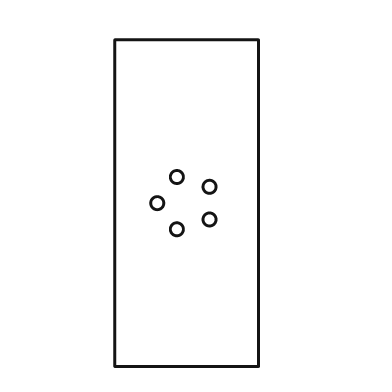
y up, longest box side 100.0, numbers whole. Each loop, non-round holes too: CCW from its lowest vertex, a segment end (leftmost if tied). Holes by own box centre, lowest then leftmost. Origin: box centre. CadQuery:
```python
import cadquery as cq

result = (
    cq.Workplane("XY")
    .moveTo(-22.0, -50.0)
    .lineTo(22.0, -50.0)
    .lineTo(22.0, 50.0)
    .lineTo(-22.0, 50.0)
    .close()
    .moveTo(-3.0, -8.0)
    .circle(2.0)
    .moveTo(7.0, -5.0)
    .circle(2.0)
    .moveTo(-9.0, 0.0)
    .circle(2.0)
    .moveTo(7.0, 5.0)
    .circle(2.0)
    .moveTo(-3.0, 8.0)
    .circle(2.0)
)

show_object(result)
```